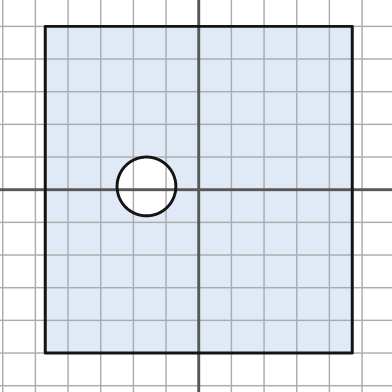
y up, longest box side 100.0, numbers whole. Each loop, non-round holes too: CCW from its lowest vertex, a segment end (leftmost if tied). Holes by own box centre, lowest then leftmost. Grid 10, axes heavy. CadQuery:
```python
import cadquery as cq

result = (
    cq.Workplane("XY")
    .moveTo(-47.0, -50.0)
    .lineTo(47.0, -50.0)
    .lineTo(47.0, 50.0)
    .lineTo(-47.0, 50.0)
    .close()
    .moveTo(-16.0, 1.0)
    .circle(9.0)
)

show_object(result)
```